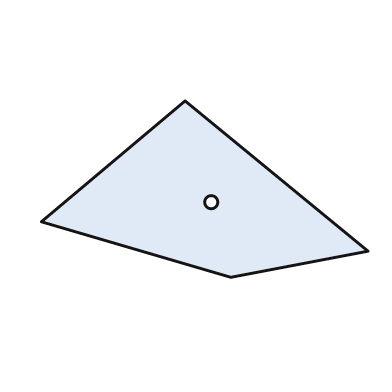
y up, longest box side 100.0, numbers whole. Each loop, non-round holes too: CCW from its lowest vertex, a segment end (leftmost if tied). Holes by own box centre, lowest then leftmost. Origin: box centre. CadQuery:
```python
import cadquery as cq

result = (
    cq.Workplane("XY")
    .moveTo(8.0, -27.0)
    .lineTo(50.0, -19.0)
    .lineTo(-6.0, 27.0)
    .lineTo(-50.0, -10.0)
    .close()
    .moveTo(2.0, -4.0)
    .circle(2.0)
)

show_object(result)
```